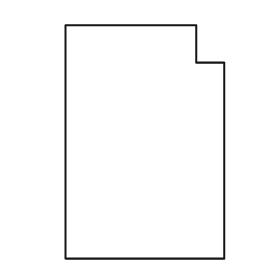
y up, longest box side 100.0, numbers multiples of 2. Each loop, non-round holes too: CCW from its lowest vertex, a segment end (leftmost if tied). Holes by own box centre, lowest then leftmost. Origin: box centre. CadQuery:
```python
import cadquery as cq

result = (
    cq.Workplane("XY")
    .moveTo(-34.0, -50.0)
    .lineTo(34.0, -50.0)
    .lineTo(34.0, 34.0)
    .lineTo(22.0, 34.0)
    .lineTo(22.0, 50.0)
    .lineTo(-34.0, 50.0)
    .close()
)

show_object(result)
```